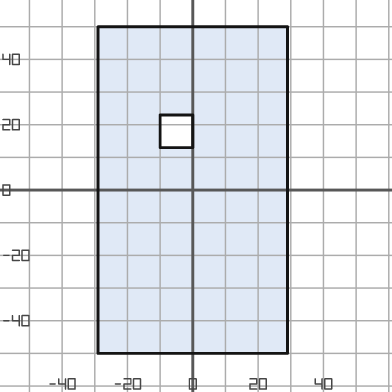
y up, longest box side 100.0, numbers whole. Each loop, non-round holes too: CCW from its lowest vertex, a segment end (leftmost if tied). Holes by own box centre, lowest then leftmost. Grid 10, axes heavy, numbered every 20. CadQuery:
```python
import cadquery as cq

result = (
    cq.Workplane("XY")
    .moveTo(-29.0, -50.0)
    .lineTo(29.0, -50.0)
    .lineTo(29.0, 50.0)
    .lineTo(-29.0, 50.0)
    .close()
    .moveTo(-10.0, 13.0)
    .lineTo(0.0, 13.0)
    .lineTo(0.0, 23.0)
    .lineTo(-10.0, 23.0)
    .close()
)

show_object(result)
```